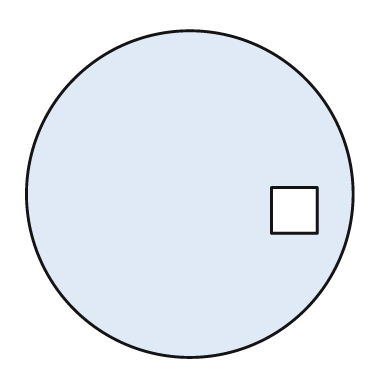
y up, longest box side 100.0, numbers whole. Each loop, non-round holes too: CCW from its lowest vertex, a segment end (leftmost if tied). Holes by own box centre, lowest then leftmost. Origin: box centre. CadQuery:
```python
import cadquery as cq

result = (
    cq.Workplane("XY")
    .moveTo(0.0, 0.0)
    .circle(50.0)
    .moveTo(25.0, -12.0)
    .lineTo(39.0, -12.0)
    .lineTo(39.0, 2.0)
    .lineTo(25.0, 2.0)
    .close()
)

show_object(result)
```